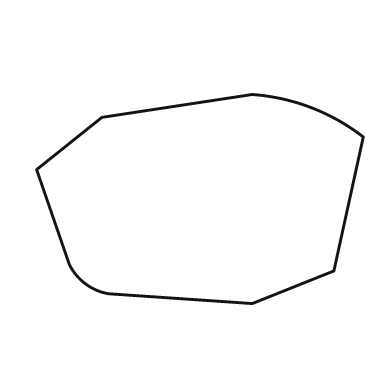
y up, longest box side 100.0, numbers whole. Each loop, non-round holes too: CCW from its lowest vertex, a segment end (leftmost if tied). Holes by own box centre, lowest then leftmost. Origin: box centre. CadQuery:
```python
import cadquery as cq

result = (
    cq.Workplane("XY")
    .moveTo(16.0, -32.0)
    .lineTo(41.0, -22.0)
    .lineTo(50.0, 19.0)
    .threePointArc((34.0, 28.0), (16.0, 32.0))
    .lineTo(-30.0, 25.0)
    .lineTo(-50.0, 9.0)
    .lineTo(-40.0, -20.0)
    .threePointArc((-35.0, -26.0), (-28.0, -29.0))
    .close()
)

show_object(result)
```